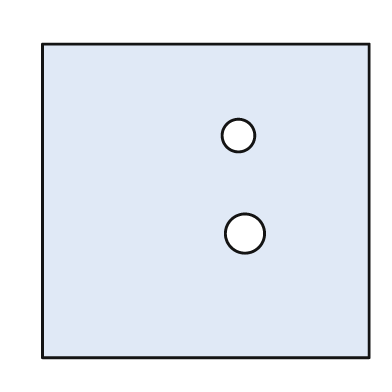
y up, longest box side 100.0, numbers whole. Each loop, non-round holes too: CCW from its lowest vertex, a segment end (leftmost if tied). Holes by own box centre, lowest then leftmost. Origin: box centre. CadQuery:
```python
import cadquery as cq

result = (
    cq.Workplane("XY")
    .moveTo(-50.0, -48.0)
    .lineTo(50.0, -48.0)
    .lineTo(50.0, 48.0)
    .lineTo(-50.0, 48.0)
    .close()
    .moveTo(12.0, -10.0)
    .circle(6.0)
    .moveTo(10.0, 20.0)
    .circle(5.0)
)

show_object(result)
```